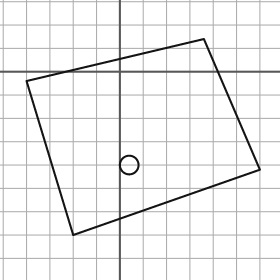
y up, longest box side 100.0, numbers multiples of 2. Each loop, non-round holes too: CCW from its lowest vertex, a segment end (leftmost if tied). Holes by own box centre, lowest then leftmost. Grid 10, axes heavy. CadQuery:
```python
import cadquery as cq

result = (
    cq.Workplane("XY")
    .moveTo(-20.0, -70.0)
    .lineTo(60.0, -42.0)
    .lineTo(36.0, 14.0)
    .lineTo(-40.0, -4.0)
    .close()
    .moveTo(4.0, -40.0)
    .circle(4.0)
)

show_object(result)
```